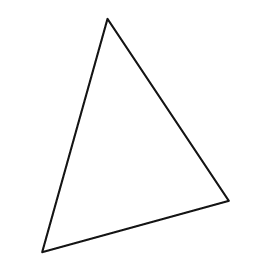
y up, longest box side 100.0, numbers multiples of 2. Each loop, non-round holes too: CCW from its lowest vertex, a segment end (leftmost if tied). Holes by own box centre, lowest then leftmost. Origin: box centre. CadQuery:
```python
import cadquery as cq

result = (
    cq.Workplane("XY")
    .moveTo(-40.0, -50.0)
    .lineTo(40.0, -28.0)
    .lineTo(-12.0, 50.0)
    .close()
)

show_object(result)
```